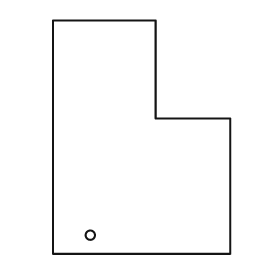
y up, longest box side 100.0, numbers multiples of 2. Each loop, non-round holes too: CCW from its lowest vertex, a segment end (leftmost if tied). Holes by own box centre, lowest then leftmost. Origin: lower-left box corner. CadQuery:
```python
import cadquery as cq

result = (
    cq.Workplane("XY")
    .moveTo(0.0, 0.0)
    .lineTo(76.0, 0.0)
    .lineTo(76.0, 58.0)
    .lineTo(44.0, 58.0)
    .lineTo(44.0, 100.0)
    .lineTo(0.0, 100.0)
    .close()
    .moveTo(16.0, 8.0)
    .circle(2.0)
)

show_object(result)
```